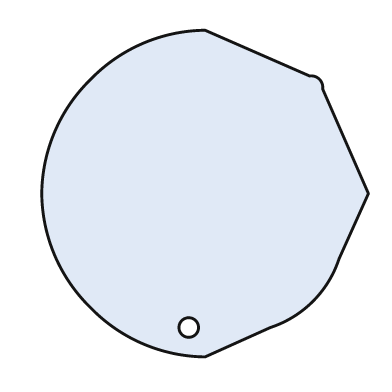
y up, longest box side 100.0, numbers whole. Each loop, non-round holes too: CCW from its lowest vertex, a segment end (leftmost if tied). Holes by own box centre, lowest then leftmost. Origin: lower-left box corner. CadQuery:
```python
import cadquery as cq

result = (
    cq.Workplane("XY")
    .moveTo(50.0, 0.0)
    .lineTo(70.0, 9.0)
    .threePointArc((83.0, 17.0), (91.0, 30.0))
    .lineTo(100.0, 50.0)
    .lineTo(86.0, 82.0)
    .threePointArc((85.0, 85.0), (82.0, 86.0))
    .lineTo(50.0, 100.0)
    .threePointArc((31.0, 96.0), (15.0, 85.0))
    .threePointArc((4.0, 69.0), (0.0, 50.0))
    .threePointArc((4.0, 31.0), (15.0, 15.0))
    .threePointArc((31.0, 4.0), (50.0, 0.0))
    .close()
    .moveTo(45.0, 9.0)
    .circle(3.0)
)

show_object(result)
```